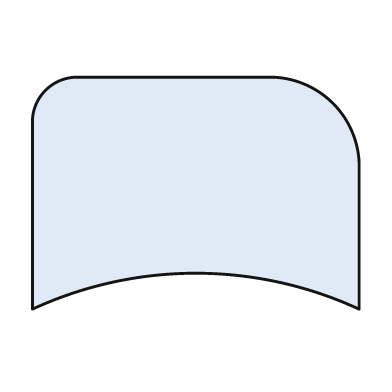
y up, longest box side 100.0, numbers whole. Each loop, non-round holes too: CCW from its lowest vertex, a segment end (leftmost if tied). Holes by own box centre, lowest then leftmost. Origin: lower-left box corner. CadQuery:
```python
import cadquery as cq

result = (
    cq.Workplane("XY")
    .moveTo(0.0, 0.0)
    .threePointArc((50.0, 11.0), (100.0, 0.0))
    .lineTo(100.0, 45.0)
    .threePointArc((92.0, 63.0), (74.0, 71.0))
    .lineTo(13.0, 71.0)
    .threePointArc((4.0, 67.0), (0.0, 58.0))
    .close()
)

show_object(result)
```